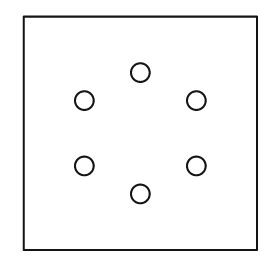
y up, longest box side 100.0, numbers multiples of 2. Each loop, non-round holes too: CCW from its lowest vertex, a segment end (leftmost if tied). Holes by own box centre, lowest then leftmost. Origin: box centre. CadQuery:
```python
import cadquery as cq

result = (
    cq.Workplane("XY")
    .moveTo(-50.0, -50.0)
    .lineTo(50.0, -50.0)
    .lineTo(50.0, 50.0)
    .lineTo(-50.0, 50.0)
    .close()
    .moveTo(0.0, -26.0)
    .circle(4.0)
    .moveTo(-24.0, -14.0)
    .circle(4.0)
    .moveTo(24.0, -14.0)
    .circle(4.0)
    .moveTo(-24.0, 14.0)
    .circle(4.0)
    .moveTo(24.0, 14.0)
    .circle(4.0)
    .moveTo(0.0, 26.0)
    .circle(4.0)
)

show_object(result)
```